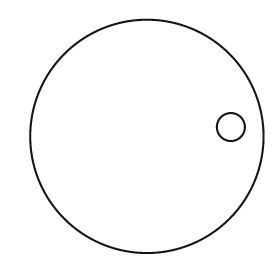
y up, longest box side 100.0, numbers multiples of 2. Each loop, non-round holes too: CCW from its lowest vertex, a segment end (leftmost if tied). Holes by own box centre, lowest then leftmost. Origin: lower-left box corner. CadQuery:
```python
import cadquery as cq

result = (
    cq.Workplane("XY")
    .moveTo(50.0, 50.0)
    .circle(50.0)
    .moveTo(86.0, 54.0)
    .circle(6.0)
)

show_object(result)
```